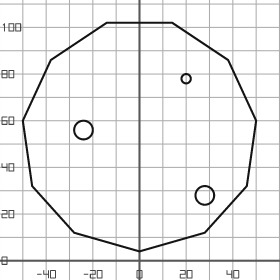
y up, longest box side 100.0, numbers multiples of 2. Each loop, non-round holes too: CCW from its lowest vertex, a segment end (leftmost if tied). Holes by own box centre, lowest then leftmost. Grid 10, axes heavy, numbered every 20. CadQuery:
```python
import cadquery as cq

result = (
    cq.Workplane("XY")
    .moveTo(0.0, 4.0)
    .lineTo(28.0, 12.0)
    .lineTo(46.0, 32.0)
    .lineTo(50.0, 60.0)
    .lineTo(38.0, 86.0)
    .lineTo(14.0, 102.0)
    .lineTo(-14.0, 102.0)
    .lineTo(-38.0, 86.0)
    .lineTo(-50.0, 60.0)
    .lineTo(-46.0, 32.0)
    .lineTo(-28.0, 12.0)
    .close()
    .moveTo(28.0, 28.0)
    .circle(4.0)
    .moveTo(-24.0, 56.0)
    .circle(4.0)
    .moveTo(20.0, 78.0)
    .circle(2.0)
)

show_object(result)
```